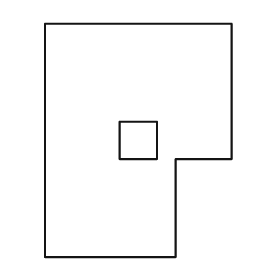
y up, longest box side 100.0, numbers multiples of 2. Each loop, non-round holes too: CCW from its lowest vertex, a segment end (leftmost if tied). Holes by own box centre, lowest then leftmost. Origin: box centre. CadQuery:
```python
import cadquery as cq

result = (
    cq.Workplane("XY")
    .moveTo(-40.0, -50.0)
    .lineTo(16.0, -50.0)
    .lineTo(16.0, -8.0)
    .lineTo(40.0, -8.0)
    .lineTo(40.0, 50.0)
    .lineTo(-40.0, 50.0)
    .close()
    .moveTo(-8.0, -8.0)
    .lineTo(8.0, -8.0)
    .lineTo(8.0, 8.0)
    .lineTo(-8.0, 8.0)
    .close()
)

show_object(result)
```